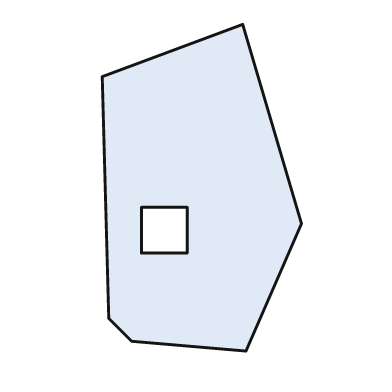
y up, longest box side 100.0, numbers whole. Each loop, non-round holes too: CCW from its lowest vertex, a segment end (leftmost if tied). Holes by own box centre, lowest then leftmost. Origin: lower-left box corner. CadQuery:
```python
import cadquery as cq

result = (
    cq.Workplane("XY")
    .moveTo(44.0, 0.0)
    .lineTo(61.0, 39.0)
    .lineTo(43.0, 100.0)
    .lineTo(0.0, 84.0)
    .lineTo(2.0, 10.0)
    .lineTo(9.0, 3.0)
    .close()
    .moveTo(12.0, 30.0)
    .lineTo(26.0, 30.0)
    .lineTo(26.0, 44.0)
    .lineTo(12.0, 44.0)
    .close()
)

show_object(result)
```